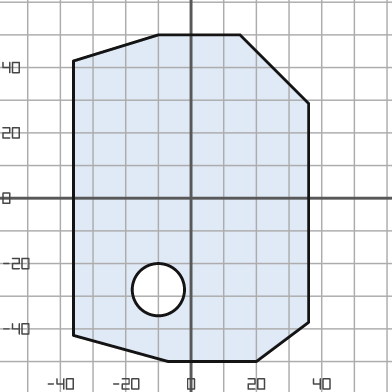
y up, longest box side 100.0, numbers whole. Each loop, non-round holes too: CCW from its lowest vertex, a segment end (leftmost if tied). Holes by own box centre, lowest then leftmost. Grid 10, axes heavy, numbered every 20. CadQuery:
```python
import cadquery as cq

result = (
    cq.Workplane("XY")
    .moveTo(-7.0, -50.0)
    .lineTo(20.0, -50.0)
    .lineTo(36.0, -38.0)
    .lineTo(36.0, 29.0)
    .lineTo(15.0, 50.0)
    .lineTo(-10.0, 50.0)
    .lineTo(-36.0, 42.0)
    .lineTo(-36.0, -42.0)
    .close()
    .moveTo(-10.0, -28.0)
    .circle(8.0)
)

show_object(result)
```